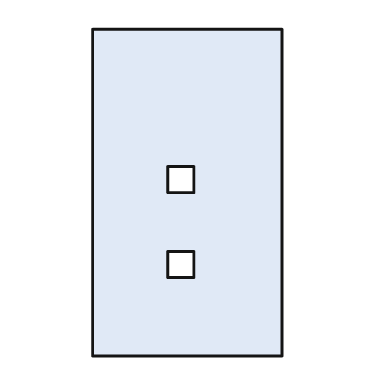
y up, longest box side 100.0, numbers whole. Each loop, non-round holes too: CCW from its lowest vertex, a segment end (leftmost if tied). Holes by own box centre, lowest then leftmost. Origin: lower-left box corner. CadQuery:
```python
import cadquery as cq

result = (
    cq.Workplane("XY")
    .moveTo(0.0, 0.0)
    .lineTo(58.0, 0.0)
    .lineTo(58.0, 100.0)
    .lineTo(0.0, 100.0)
    .close()
    .moveTo(23.0, 24.0)
    .lineTo(31.0, 24.0)
    .lineTo(31.0, 32.0)
    .lineTo(23.0, 32.0)
    .close()
    .moveTo(23.0, 50.0)
    .lineTo(31.0, 50.0)
    .lineTo(31.0, 58.0)
    .lineTo(23.0, 58.0)
    .close()
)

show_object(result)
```